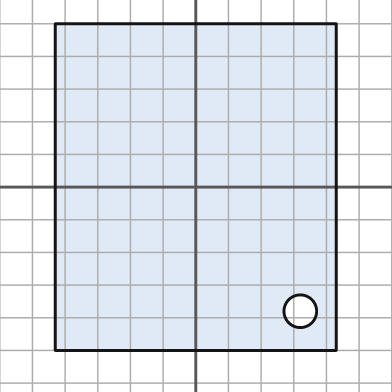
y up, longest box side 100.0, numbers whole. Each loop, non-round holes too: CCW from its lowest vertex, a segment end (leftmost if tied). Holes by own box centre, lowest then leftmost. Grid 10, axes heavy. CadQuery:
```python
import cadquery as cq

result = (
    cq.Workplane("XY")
    .moveTo(-43.0, -50.0)
    .lineTo(43.0, -50.0)
    .lineTo(43.0, 50.0)
    .lineTo(-43.0, 50.0)
    .close()
    .moveTo(32.0, -38.0)
    .circle(5.0)
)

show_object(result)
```